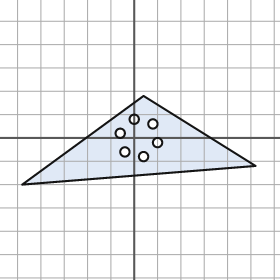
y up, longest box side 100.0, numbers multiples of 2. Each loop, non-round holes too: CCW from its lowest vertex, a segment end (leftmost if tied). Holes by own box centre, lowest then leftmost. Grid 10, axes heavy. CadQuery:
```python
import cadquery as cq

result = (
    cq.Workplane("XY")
    .moveTo(-48.0, -20.0)
    .lineTo(52.0, -12.0)
    .lineTo(4.0, 18.0)
    .close()
    .moveTo(4.0, -8.0)
    .circle(2.0)
    .moveTo(-4.0, -6.0)
    .circle(2.0)
    .moveTo(10.0, -2.0)
    .circle(2.0)
    .moveTo(-6.0, 2.0)
    .circle(2.0)
    .moveTo(8.0, 6.0)
    .circle(2.0)
    .moveTo(0.0, 8.0)
    .circle(2.0)
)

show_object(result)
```